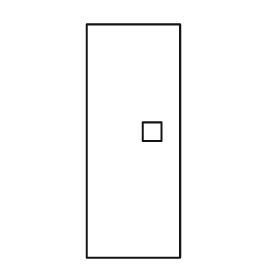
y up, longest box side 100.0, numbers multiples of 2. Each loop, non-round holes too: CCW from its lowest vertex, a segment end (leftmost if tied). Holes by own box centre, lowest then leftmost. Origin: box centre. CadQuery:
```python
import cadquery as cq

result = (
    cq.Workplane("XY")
    .moveTo(-20.0, -50.0)
    .lineTo(20.0, -50.0)
    .lineTo(20.0, 50.0)
    .lineTo(-20.0, 50.0)
    .close()
    .moveTo(4.0, 0.0)
    .lineTo(12.0, 0.0)
    .lineTo(12.0, 8.0)
    .lineTo(4.0, 8.0)
    .close()
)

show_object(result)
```